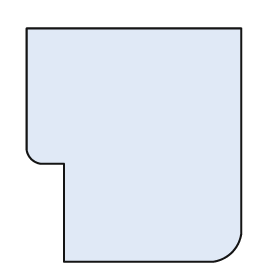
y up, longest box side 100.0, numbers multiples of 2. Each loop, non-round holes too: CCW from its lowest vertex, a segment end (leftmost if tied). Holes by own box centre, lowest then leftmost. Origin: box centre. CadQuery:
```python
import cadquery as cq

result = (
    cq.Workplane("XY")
    .moveTo(-30.0, -50.0)
    .lineTo(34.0, -50.0)
    .threePointArc((42.0, -46.0), (46.0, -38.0))
    .lineTo(46.0, 50.0)
    .lineTo(-46.0, 50.0)
    .lineTo(-46.0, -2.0)
    .threePointArc((-44.0, -6.0), (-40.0, -8.0))
    .lineTo(-30.0, -8.0)
    .close()
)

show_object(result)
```